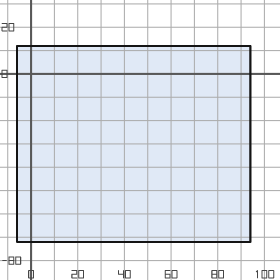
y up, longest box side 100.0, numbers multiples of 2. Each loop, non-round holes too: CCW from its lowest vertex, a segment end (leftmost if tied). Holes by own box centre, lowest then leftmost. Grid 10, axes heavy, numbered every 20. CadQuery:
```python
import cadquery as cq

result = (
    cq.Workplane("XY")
    .moveTo(-6.0, -72.0)
    .lineTo(94.0, -72.0)
    .lineTo(94.0, 12.0)
    .lineTo(-6.0, 12.0)
    .close()
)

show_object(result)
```